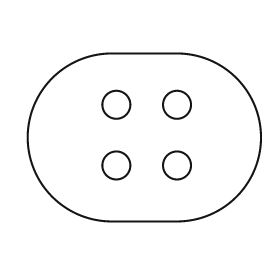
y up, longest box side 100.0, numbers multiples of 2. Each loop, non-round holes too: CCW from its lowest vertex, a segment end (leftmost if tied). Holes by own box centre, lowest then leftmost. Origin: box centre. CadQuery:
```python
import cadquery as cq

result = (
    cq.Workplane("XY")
    .moveTo(-14.0, -36.0)
    .lineTo(14.0, -36.0)
    .threePointArc((50.0, 0.0), (14.0, 36.0))
    .lineTo(-14.0, 36.0)
    .threePointArc((-50.0, 0.0), (-14.0, -36.0))
    .close()
    .moveTo(-12.0, -12.0)
    .circle(6.0)
    .moveTo(14.0, -12.0)
    .circle(6.0)
    .moveTo(-12.0, 14.0)
    .circle(6.0)
    .moveTo(14.0, 14.0)
    .circle(6.0)
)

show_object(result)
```